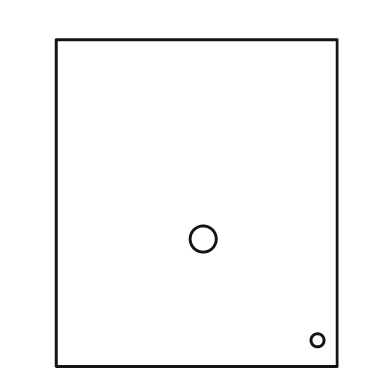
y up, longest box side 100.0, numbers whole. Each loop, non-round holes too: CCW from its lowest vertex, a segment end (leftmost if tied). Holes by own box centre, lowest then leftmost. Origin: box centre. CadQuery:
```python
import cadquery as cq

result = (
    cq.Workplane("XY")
    .moveTo(-43.0, -50.0)
    .lineTo(43.0, -50.0)
    .lineTo(43.0, 50.0)
    .lineTo(-43.0, 50.0)
    .close()
    .moveTo(37.0, -42.0)
    .circle(2.0)
    .moveTo(2.0, -11.0)
    .circle(4.0)
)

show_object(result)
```